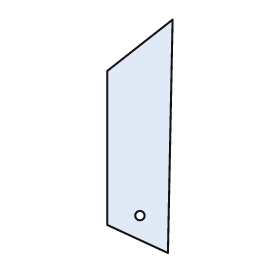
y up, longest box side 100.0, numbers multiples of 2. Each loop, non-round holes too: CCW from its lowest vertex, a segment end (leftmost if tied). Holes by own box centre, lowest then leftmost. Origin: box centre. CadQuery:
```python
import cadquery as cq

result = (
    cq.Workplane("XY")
    .moveTo(12.0, -50.0)
    .lineTo(14.0, 50.0)
    .lineTo(-14.0, 28.0)
    .lineTo(-14.0, -38.0)
    .close()
    .moveTo(0.0, -34.0)
    .circle(2.0)
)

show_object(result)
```